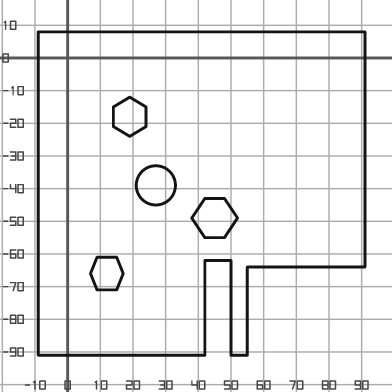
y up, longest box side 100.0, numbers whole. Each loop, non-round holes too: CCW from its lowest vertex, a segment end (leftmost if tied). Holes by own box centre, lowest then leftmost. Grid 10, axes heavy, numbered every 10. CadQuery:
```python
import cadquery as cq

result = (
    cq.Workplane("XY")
    .moveTo(-9.0, -91.0)
    .lineTo(42.0, -91.0)
    .lineTo(42.0, -62.0)
    .lineTo(50.0, -62.0)
    .lineTo(50.0, -91.0)
    .lineTo(55.0, -91.0)
    .lineTo(55.0, -64.0)
    .lineTo(91.0, -64.0)
    .lineTo(91.0, 8.0)
    .lineTo(-9.0, 8.0)
    .close()
    .moveTo(9.0, -71.0)
    .lineTo(15.0, -71.0)
    .lineTo(17.0, -66.0)
    .lineTo(15.0, -61.0)
    .lineTo(9.0, -61.0)
    .lineTo(7.0, -66.0)
    .close()
    .moveTo(42.0, -55.0)
    .lineTo(48.0, -55.0)
    .lineTo(52.0, -49.0)
    .lineTo(48.0, -43.0)
    .lineTo(42.0, -43.0)
    .lineTo(38.0, -49.0)
    .close()
    .moveTo(27.0, -39.0)
    .circle(6.0)
    .moveTo(19.0, -24.0)
    .lineTo(24.0, -21.0)
    .lineTo(24.0, -15.0)
    .lineTo(19.0, -12.0)
    .lineTo(14.0, -15.0)
    .lineTo(14.0, -21.0)
    .close()
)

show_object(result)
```